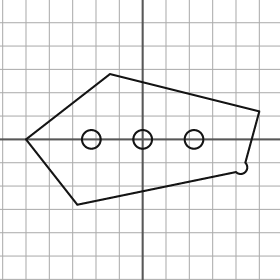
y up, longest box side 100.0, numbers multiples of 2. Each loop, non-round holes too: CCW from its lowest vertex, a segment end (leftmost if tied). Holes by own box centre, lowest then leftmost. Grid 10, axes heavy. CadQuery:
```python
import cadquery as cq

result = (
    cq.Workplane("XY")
    .moveTo(-28.0, -28.0)
    .lineTo(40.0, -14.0)
    .threePointArc((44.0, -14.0), (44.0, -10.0))
    .lineTo(50.0, 12.0)
    .lineTo(-14.0, 28.0)
    .lineTo(-50.0, 0.0)
    .close()
    .moveTo(-22.0, 0.0)
    .circle(4.0)
    .moveTo(0.0, 0.0)
    .circle(4.0)
    .moveTo(22.0, 0.0)
    .circle(4.0)
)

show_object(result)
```